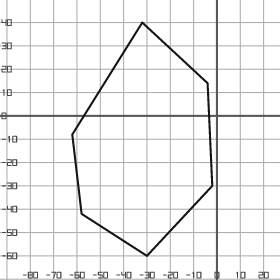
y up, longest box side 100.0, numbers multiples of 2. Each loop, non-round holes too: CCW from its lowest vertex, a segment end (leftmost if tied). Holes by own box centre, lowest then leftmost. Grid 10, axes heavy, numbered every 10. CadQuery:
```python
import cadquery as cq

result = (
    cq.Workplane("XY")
    .moveTo(-30.0, -60.0)
    .lineTo(-2.0, -30.0)
    .lineTo(-4.0, 14.0)
    .lineTo(-32.0, 40.0)
    .lineTo(-62.0, -8.0)
    .lineTo(-58.0, -42.0)
    .close()
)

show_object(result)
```